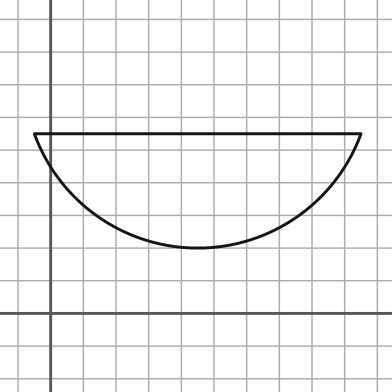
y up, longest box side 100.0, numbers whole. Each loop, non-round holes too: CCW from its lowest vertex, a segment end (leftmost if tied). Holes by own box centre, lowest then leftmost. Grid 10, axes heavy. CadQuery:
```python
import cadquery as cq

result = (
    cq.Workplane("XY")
    .moveTo(-5.0, 55.0)
    .threePointArc((45.0, 20.0), (95.0, 55.0))
    .close()
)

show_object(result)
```